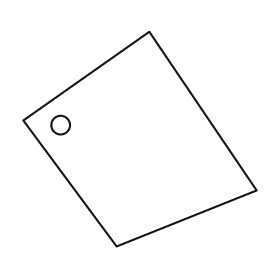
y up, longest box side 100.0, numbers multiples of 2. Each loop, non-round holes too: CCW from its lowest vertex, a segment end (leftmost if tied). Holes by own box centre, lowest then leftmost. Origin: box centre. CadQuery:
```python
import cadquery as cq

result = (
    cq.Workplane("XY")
    .moveTo(-10.0, -46.0)
    .lineTo(50.0, -22.0)
    .lineTo(4.0, 46.0)
    .lineTo(-50.0, 8.0)
    .close()
    .moveTo(-34.0, 6.0)
    .circle(4.0)
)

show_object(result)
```